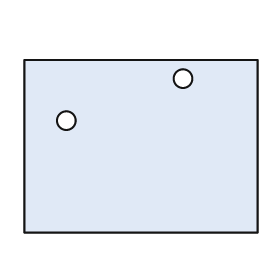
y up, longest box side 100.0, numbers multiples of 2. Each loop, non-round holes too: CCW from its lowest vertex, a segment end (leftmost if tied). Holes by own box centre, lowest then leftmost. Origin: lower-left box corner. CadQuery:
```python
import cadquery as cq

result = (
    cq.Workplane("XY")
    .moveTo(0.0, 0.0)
    .lineTo(100.0, 0.0)
    .lineTo(100.0, 74.0)
    .lineTo(0.0, 74.0)
    .close()
    .moveTo(18.0, 48.0)
    .circle(4.0)
    .moveTo(68.0, 66.0)
    .circle(4.0)
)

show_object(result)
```